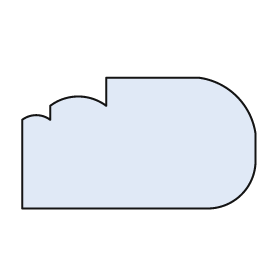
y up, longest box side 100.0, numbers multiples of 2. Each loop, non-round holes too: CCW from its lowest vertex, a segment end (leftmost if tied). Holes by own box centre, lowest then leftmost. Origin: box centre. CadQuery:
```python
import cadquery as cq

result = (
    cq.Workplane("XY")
    .moveTo(-50.0, -28.0)
    .lineTo(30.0, -28.0)
    .threePointArc((44.0, -22.0), (50.0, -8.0))
    .lineTo(50.0, 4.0)
    .threePointArc((42.0, 20.0), (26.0, 28.0))
    .lineTo(-14.0, 28.0)
    .lineTo(-14.0, 16.0)
    .threePointArc((-26.0, 20.0), (-38.0, 16.0))
    .lineTo(-38.0, 10.0)
    .threePointArc((-44.0, 12.0), (-50.0, 10.0))
    .close()
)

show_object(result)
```